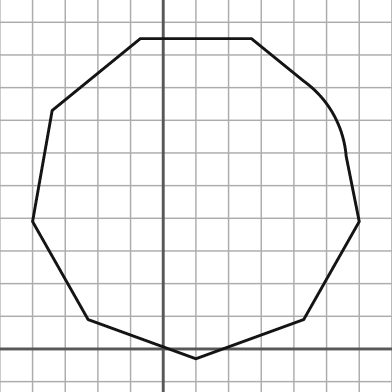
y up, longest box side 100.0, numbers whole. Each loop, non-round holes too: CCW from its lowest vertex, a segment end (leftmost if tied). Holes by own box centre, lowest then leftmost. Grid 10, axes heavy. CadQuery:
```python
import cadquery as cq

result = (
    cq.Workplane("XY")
    .moveTo(10.0, -3.0)
    .lineTo(43.0, 9.0)
    .lineTo(60.0, 39.0)
    .lineTo(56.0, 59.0)
    .threePointArc((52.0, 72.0), (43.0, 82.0))
    .lineTo(27.0, 95.0)
    .lineTo(-7.0, 95.0)
    .lineTo(-34.0, 73.0)
    .lineTo(-40.0, 39.0)
    .lineTo(-23.0, 9.0)
    .close()
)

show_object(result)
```